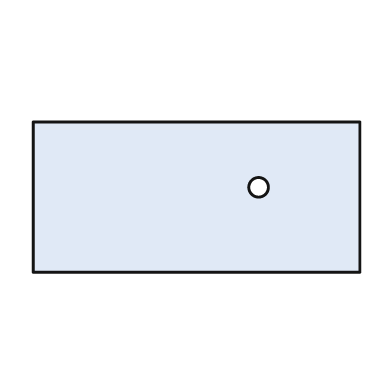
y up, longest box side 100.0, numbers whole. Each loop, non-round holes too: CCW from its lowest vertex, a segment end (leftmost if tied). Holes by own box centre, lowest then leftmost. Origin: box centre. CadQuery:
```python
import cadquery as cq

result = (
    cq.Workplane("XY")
    .moveTo(-50.0, -23.0)
    .lineTo(50.0, -23.0)
    .lineTo(50.0, 23.0)
    .lineTo(-50.0, 23.0)
    .close()
    .moveTo(19.0, 3.0)
    .circle(3.0)
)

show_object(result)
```